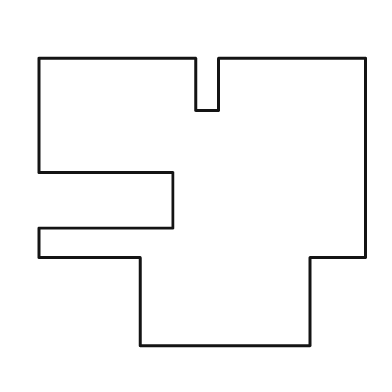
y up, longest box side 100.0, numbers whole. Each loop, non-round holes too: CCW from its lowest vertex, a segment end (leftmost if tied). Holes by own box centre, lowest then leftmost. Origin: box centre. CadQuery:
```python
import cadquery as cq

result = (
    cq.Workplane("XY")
    .moveTo(-19.0, -44.0)
    .lineTo(33.0, -44.0)
    .lineTo(33.0, -17.0)
    .lineTo(50.0, -17.0)
    .lineTo(50.0, 44.0)
    .lineTo(5.0, 44.0)
    .lineTo(5.0, 28.0)
    .lineTo(-2.0, 28.0)
    .lineTo(-2.0, 44.0)
    .lineTo(-50.0, 44.0)
    .lineTo(-50.0, 9.0)
    .lineTo(-9.0, 9.0)
    .lineTo(-9.0, -8.0)
    .lineTo(-50.0, -8.0)
    .lineTo(-50.0, -17.0)
    .lineTo(-19.0, -17.0)
    .close()
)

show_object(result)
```